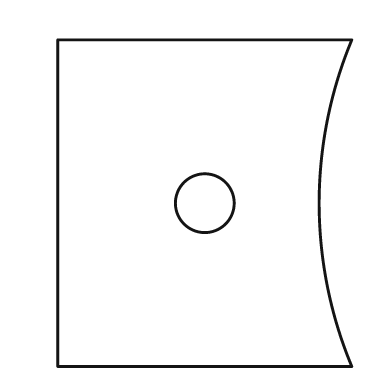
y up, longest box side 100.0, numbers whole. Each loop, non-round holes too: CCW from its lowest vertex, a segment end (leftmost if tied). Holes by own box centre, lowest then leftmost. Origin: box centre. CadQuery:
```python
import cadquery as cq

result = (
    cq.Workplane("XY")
    .moveTo(-45.0, -50.0)
    .lineTo(45.0, -50.0)
    .threePointArc((35.0, 0.0), (45.0, 50.0))
    .lineTo(-45.0, 50.0)
    .close()
    .moveTo(0.0, 0.0)
    .circle(9.0)
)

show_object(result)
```